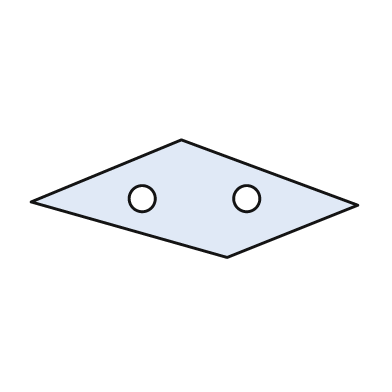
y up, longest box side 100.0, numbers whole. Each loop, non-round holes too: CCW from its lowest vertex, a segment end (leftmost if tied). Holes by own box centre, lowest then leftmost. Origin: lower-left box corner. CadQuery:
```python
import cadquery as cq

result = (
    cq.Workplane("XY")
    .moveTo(60.0, 0.0)
    .lineTo(100.0, 16.0)
    .lineTo(46.0, 36.0)
    .lineTo(0.0, 17.0)
    .close()
    .moveTo(34.0, 18.0)
    .circle(4.0)
    .moveTo(66.0, 18.0)
    .circle(4.0)
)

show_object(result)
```